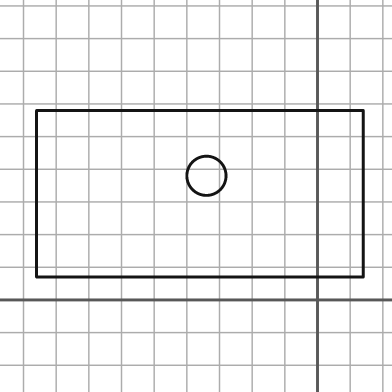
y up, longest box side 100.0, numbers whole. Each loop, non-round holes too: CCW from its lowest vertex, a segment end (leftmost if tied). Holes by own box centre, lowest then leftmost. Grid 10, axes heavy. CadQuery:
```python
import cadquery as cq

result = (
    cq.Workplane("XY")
    .moveTo(-86.0, 7.0)
    .lineTo(14.0, 7.0)
    .lineTo(14.0, 58.0)
    .lineTo(-86.0, 58.0)
    .close()
    .moveTo(-34.0, 38.0)
    .circle(6.0)
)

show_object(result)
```